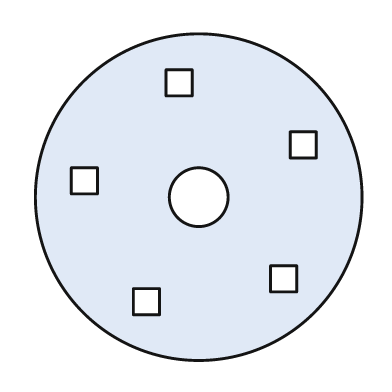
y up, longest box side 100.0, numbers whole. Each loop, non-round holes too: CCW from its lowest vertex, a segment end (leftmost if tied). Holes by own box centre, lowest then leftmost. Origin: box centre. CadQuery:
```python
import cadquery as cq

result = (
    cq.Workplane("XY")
    .moveTo(0.0, 0.0)
    .circle(50.0)
    .moveTo(-20.0, -36.0)
    .lineTo(-12.0, -36.0)
    .lineTo(-12.0, -28.0)
    .lineTo(-20.0, -28.0)
    .close()
    .moveTo(22.0, -29.0)
    .lineTo(30.0, -29.0)
    .lineTo(30.0, -21.0)
    .lineTo(22.0, -21.0)
    .close()
    .moveTo(0.0, 0.0)
    .circle(9.0)
    .moveTo(-39.0, 1.0)
    .lineTo(-31.0, 1.0)
    .lineTo(-31.0, 9.0)
    .lineTo(-39.0, 9.0)
    .close()
    .moveTo(28.0, 12.0)
    .lineTo(36.0, 12.0)
    .lineTo(36.0, 20.0)
    .lineTo(28.0, 20.0)
    .close()
    .moveTo(-10.0, 31.0)
    .lineTo(-2.0, 31.0)
    .lineTo(-2.0, 39.0)
    .lineTo(-10.0, 39.0)
    .close()
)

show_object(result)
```